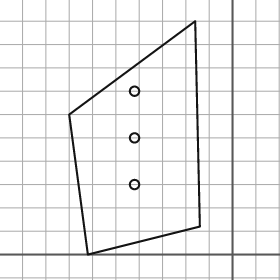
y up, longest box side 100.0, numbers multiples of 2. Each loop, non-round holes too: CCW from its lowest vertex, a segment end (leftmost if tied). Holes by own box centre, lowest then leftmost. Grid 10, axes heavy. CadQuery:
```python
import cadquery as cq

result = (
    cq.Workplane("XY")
    .moveTo(-62.0, 0.0)
    .lineTo(-14.0, 12.0)
    .lineTo(-16.0, 100.0)
    .lineTo(-70.0, 60.0)
    .close()
    .moveTo(-42.0, 30.0)
    .circle(2.0)
    .moveTo(-42.0, 50.0)
    .circle(2.0)
    .moveTo(-42.0, 70.0)
    .circle(2.0)
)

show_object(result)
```